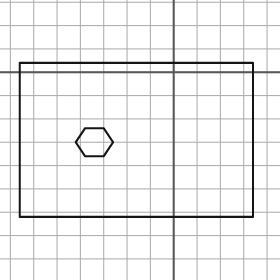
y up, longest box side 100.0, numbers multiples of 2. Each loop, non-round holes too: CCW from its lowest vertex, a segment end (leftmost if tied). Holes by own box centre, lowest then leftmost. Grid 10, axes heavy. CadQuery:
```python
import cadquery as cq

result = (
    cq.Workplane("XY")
    .moveTo(-66.0, -62.0)
    .lineTo(34.0, -62.0)
    .lineTo(34.0, 4.0)
    .lineTo(-66.0, 4.0)
    .close()
    .moveTo(-38.0, -36.0)
    .lineTo(-30.0, -36.0)
    .lineTo(-26.0, -30.0)
    .lineTo(-30.0, -24.0)
    .lineTo(-38.0, -24.0)
    .lineTo(-42.0, -30.0)
    .close()
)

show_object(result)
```